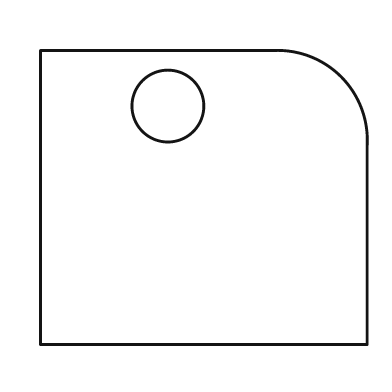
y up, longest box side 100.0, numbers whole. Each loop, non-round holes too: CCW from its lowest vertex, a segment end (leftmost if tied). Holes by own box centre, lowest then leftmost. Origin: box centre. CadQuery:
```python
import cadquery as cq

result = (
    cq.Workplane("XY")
    .moveTo(-50.0, -45.0)
    .lineTo(50.0, -45.0)
    .lineTo(50.0, 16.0)
    .threePointArc((42.0, 37.0), (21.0, 45.0))
    .lineTo(-50.0, 45.0)
    .close()
    .moveTo(-11.0, 28.0)
    .circle(11.0)
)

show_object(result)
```